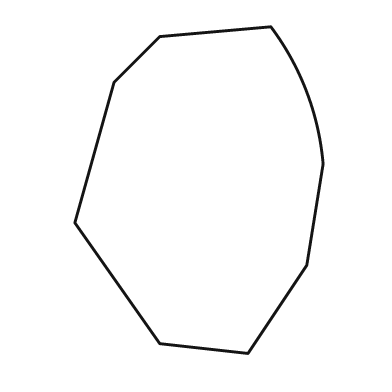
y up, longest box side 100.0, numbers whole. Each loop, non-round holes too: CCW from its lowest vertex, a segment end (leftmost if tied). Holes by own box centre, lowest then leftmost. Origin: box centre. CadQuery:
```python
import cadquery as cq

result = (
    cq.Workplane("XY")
    .moveTo(15.0, -50.0)
    .lineTo(33.0, -23.0)
    .lineTo(38.0, 8.0)
    .threePointArc((33.0, 30.0), (22.0, 50.0))
    .lineTo(-12.0, 47.0)
    .lineTo(-26.0, 33.0)
    .lineTo(-38.0, -10.0)
    .lineTo(-12.0, -47.0)
    .close()
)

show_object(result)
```